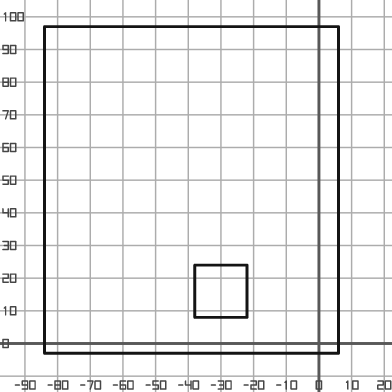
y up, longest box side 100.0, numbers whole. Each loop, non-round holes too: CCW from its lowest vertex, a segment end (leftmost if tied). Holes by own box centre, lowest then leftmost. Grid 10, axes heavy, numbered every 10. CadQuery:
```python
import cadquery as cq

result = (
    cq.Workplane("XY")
    .moveTo(-84.0, -3.0)
    .lineTo(6.0, -3.0)
    .lineTo(6.0, 97.0)
    .lineTo(-84.0, 97.0)
    .close()
    .moveTo(-38.0, 8.0)
    .lineTo(-22.0, 8.0)
    .lineTo(-22.0, 24.0)
    .lineTo(-38.0, 24.0)
    .close()
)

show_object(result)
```